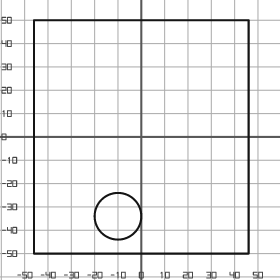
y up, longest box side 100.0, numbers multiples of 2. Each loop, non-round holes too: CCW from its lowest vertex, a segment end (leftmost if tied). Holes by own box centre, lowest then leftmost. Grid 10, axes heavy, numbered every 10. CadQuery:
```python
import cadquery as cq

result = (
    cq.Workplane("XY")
    .moveTo(-46.0, -50.0)
    .lineTo(46.0, -50.0)
    .lineTo(46.0, 50.0)
    .lineTo(-46.0, 50.0)
    .close()
    .moveTo(-10.0, -34.0)
    .circle(10.0)
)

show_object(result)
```